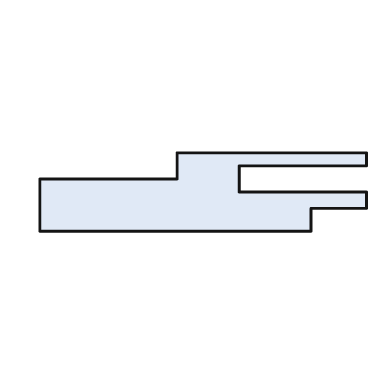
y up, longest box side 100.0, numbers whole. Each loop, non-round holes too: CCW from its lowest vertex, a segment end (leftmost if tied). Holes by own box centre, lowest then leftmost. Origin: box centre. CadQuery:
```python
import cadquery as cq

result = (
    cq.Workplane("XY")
    .moveTo(-50.0, -12.0)
    .lineTo(33.0, -12.0)
    .lineTo(33.0, -5.0)
    .lineTo(50.0, -5.0)
    .lineTo(50.0, 0.0)
    .lineTo(11.0, 0.0)
    .lineTo(11.0, 8.0)
    .lineTo(50.0, 8.0)
    .lineTo(50.0, 12.0)
    .lineTo(-8.0, 12.0)
    .lineTo(-8.0, 4.0)
    .lineTo(-50.0, 4.0)
    .close()
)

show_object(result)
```